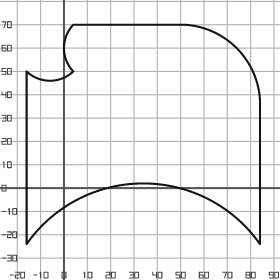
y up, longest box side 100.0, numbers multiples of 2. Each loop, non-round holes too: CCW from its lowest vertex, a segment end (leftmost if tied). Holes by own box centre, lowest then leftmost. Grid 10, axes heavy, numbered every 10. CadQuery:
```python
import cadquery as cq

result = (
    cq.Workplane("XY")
    .moveTo(-16.0, -24.0)
    .threePointArc((34.0, 2.0), (84.0, -24.0))
    .lineTo(84.0, 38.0)
    .threePointArc((74.0, 60.0), (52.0, 70.0))
    .lineTo(4.0, 70.0)
    .threePointArc((0.0, 60.0), (4.0, 50.0))
    .threePointArc((-6.0, 46.0), (-16.0, 50.0))
    .close()
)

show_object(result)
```